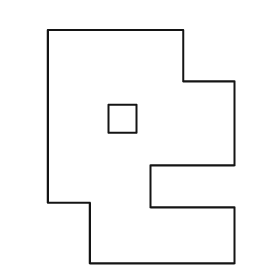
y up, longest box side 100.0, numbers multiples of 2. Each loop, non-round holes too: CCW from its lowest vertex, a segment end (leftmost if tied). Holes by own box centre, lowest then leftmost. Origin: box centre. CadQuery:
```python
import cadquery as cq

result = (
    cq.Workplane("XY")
    .moveTo(-22.0, -50.0)
    .lineTo(40.0, -50.0)
    .lineTo(40.0, -26.0)
    .lineTo(4.0, -26.0)
    .lineTo(4.0, -8.0)
    .lineTo(40.0, -8.0)
    .lineTo(40.0, 28.0)
    .lineTo(18.0, 28.0)
    .lineTo(18.0, 50.0)
    .lineTo(-40.0, 50.0)
    .lineTo(-40.0, -24.0)
    .lineTo(-22.0, -24.0)
    .close()
    .moveTo(-14.0, 6.0)
    .lineTo(-2.0, 6.0)
    .lineTo(-2.0, 18.0)
    .lineTo(-14.0, 18.0)
    .close()
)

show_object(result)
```